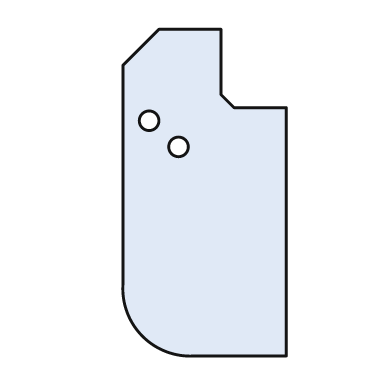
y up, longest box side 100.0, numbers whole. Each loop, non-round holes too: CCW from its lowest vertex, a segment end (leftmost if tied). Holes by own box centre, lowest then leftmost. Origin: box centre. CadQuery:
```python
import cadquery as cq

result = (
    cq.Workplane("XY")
    .moveTo(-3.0, -50.0)
    .lineTo(25.0, -50.0)
    .lineTo(25.0, 26.0)
    .lineTo(9.0, 26.0)
    .lineTo(5.0, 30.0)
    .lineTo(5.0, 50.0)
    .lineTo(-14.0, 50.0)
    .lineTo(-25.0, 39.0)
    .lineTo(-25.0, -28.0)
    .threePointArc((-19.0, -44.0), (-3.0, -50.0))
    .close()
    .moveTo(-8.0, 14.0)
    .circle(3.0)
    .moveTo(-17.0, 22.0)
    .circle(3.0)
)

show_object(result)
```